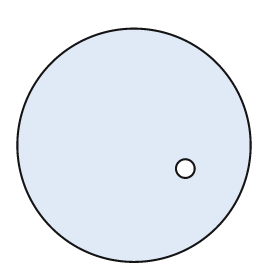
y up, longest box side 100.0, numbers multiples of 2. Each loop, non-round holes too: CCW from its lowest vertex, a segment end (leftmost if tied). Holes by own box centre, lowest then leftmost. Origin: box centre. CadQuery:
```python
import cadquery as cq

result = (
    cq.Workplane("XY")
    .moveTo(0.0, 0.0)
    .circle(50.0)
    .moveTo(22.0, -10.0)
    .circle(4.0)
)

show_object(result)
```